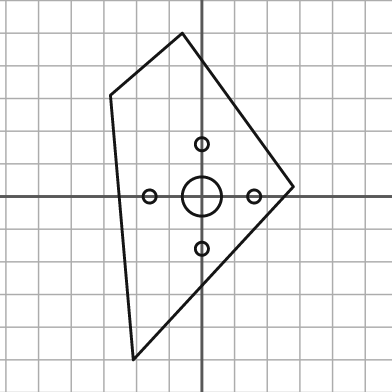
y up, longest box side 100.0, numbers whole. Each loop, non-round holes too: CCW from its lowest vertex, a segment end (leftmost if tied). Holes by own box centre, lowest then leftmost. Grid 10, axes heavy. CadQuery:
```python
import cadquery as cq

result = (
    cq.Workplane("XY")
    .moveTo(-21.0, -50.0)
    .lineTo(28.0, 3.0)
    .lineTo(-6.0, 50.0)
    .lineTo(-28.0, 31.0)
    .close()
    .moveTo(0.0, -16.0)
    .circle(2.0)
    .moveTo(-16.0, 0.0)
    .circle(2.0)
    .moveTo(0.0, 0.0)
    .circle(6.0)
    .moveTo(16.0, 0.0)
    .circle(2.0)
    .moveTo(0.0, 16.0)
    .circle(2.0)
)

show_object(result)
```